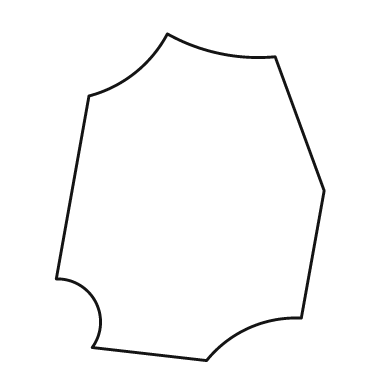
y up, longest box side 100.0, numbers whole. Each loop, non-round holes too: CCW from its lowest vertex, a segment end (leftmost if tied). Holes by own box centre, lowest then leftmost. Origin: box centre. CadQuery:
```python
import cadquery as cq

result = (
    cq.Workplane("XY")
    .moveTo(5.0, -50.0)
    .threePointArc((18.0, -40.0), (34.0, -37.0))
    .lineTo(41.0, 2.0)
    .lineTo(26.0, 43.0)
    .threePointArc((9.0, 44.0), (-7.0, 50.0))
    .threePointArc((-17.0, 38.0), (-31.0, 31.0))
    .lineTo(-41.0, -25.0)
    .threePointArc((-29.0, -32.0), (-30.0, -46.0))
    .close()
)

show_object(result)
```